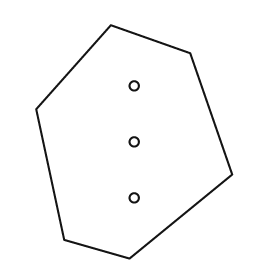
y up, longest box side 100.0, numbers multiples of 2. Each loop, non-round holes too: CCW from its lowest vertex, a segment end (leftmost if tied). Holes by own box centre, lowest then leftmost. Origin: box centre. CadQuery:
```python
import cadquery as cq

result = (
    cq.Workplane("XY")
    .moveTo(-2.0, -50.0)
    .lineTo(42.0, -14.0)
    .lineTo(24.0, 38.0)
    .lineTo(-10.0, 50.0)
    .lineTo(-42.0, 14.0)
    .lineTo(-30.0, -42.0)
    .close()
    .moveTo(0.0, -24.0)
    .circle(2.0)
    .moveTo(0.0, 0.0)
    .circle(2.0)
    .moveTo(0.0, 24.0)
    .circle(2.0)
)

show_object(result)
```